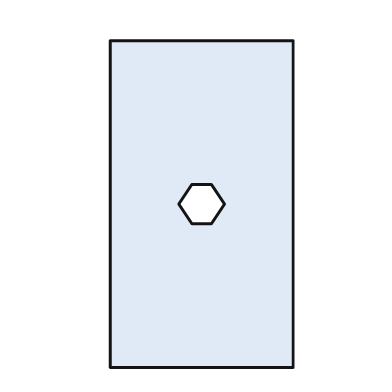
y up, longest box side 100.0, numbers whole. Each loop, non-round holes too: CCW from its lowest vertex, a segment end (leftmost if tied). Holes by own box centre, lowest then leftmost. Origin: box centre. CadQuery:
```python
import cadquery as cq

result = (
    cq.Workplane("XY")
    .moveTo(-28.0, -50.0)
    .lineTo(28.0, -50.0)
    .lineTo(28.0, 50.0)
    .lineTo(-28.0, 50.0)
    .close()
    .moveTo(-3.0, -6.0)
    .lineTo(3.0, -6.0)
    .lineTo(7.0, 0.0)
    .lineTo(3.0, 6.0)
    .lineTo(-3.0, 6.0)
    .lineTo(-7.0, 0.0)
    .close()
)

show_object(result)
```